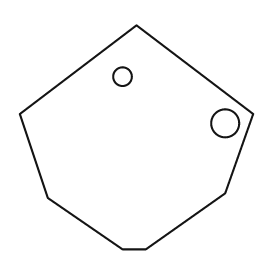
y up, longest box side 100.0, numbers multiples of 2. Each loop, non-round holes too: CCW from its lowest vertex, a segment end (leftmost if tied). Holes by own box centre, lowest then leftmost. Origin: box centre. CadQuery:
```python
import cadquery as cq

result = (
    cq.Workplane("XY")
    .moveTo(-6.0, -48.0)
    .lineTo(4.0, -48.0)
    .lineTo(38.0, -24.0)
    .lineTo(50.0, 10.0)
    .lineTo(0.0, 48.0)
    .lineTo(-50.0, 10.0)
    .lineTo(-38.0, -26.0)
    .close()
    .moveTo(38.0, 6.0)
    .circle(6.0)
    .moveTo(-6.0, 26.0)
    .circle(4.0)
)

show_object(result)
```